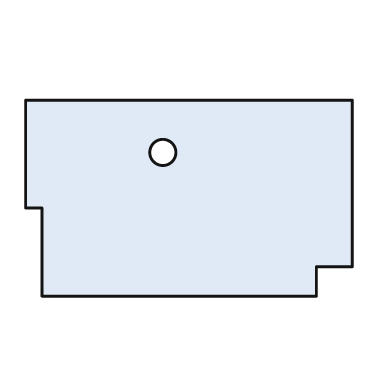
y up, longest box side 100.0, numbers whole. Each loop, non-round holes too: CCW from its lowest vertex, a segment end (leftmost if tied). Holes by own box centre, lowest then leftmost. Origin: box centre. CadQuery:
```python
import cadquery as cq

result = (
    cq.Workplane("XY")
    .moveTo(-45.0, -30.0)
    .lineTo(39.0, -30.0)
    .lineTo(39.0, -21.0)
    .lineTo(50.0, -21.0)
    .lineTo(50.0, 30.0)
    .lineTo(-50.0, 30.0)
    .lineTo(-50.0, -3.0)
    .lineTo(-45.0, -3.0)
    .close()
    .moveTo(-8.0, 14.0)
    .circle(4.0)
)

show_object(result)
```